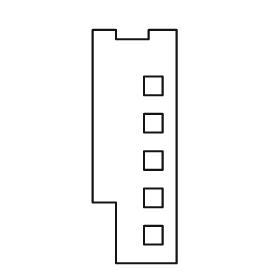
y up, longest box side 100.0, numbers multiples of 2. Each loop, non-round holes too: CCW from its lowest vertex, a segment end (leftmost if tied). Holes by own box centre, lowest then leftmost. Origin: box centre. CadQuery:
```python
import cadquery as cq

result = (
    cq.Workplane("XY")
    .moveTo(-8.0, -50.0)
    .lineTo(18.0, -50.0)
    .lineTo(18.0, 50.0)
    .lineTo(6.0, 50.0)
    .lineTo(6.0, 46.0)
    .lineTo(-8.0, 46.0)
    .lineTo(-8.0, 50.0)
    .lineTo(-18.0, 50.0)
    .lineTo(-18.0, -24.0)
    .lineTo(-8.0, -24.0)
    .close()
    .moveTo(4.0, -42.0)
    .lineTo(12.0, -42.0)
    .lineTo(12.0, -34.0)
    .lineTo(4.0, -34.0)
    .close()
    .moveTo(4.0, -26.0)
    .lineTo(12.0, -26.0)
    .lineTo(12.0, -18.0)
    .lineTo(4.0, -18.0)
    .close()
    .moveTo(4.0, -10.0)
    .lineTo(12.0, -10.0)
    .lineTo(12.0, -2.0)
    .lineTo(4.0, -2.0)
    .close()
    .moveTo(4.0, 6.0)
    .lineTo(12.0, 6.0)
    .lineTo(12.0, 14.0)
    .lineTo(4.0, 14.0)
    .close()
    .moveTo(4.0, 22.0)
    .lineTo(12.0, 22.0)
    .lineTo(12.0, 30.0)
    .lineTo(4.0, 30.0)
    .close()
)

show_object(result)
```